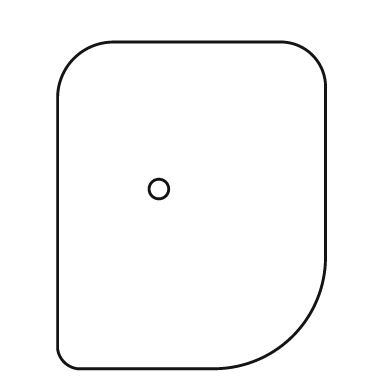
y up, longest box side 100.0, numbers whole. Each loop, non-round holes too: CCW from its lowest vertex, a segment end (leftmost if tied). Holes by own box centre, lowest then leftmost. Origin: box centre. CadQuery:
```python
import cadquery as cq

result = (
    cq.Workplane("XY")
    .moveTo(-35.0, -50.0)
    .lineTo(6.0, -50.0)
    .threePointArc((31.0, -40.0), (41.0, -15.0))
    .lineTo(41.0, 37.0)
    .threePointArc((37.0, 46.0), (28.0, 50.0))
    .lineTo(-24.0, 50.0)
    .threePointArc((-36.0, 45.0), (-41.0, 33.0))
    .lineTo(-41.0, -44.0)
    .threePointArc((-39.0, -48.0), (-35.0, -50.0))
    .close()
    .moveTo(-10.0, 5.0)
    .circle(3.0)
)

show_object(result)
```